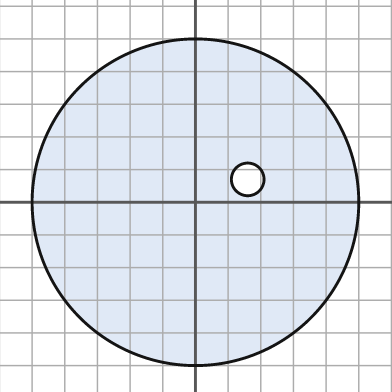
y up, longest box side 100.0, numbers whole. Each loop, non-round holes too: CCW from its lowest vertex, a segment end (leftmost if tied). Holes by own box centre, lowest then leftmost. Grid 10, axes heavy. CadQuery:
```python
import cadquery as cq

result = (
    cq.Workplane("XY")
    .moveTo(0.0, 0.0)
    .circle(50.0)
    .moveTo(16.0, 7.0)
    .circle(5.0)
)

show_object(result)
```